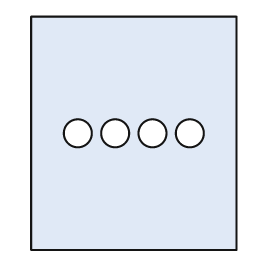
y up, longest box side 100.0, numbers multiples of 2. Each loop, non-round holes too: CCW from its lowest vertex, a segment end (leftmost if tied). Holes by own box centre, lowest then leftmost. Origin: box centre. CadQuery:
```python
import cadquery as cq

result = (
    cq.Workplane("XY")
    .moveTo(-44.0, -50.0)
    .lineTo(44.0, -50.0)
    .lineTo(44.0, 50.0)
    .lineTo(-44.0, 50.0)
    .close()
    .moveTo(-24.0, 0.0)
    .circle(6.0)
    .moveTo(-8.0, 0.0)
    .circle(6.0)
    .moveTo(8.0, 0.0)
    .circle(6.0)
    .moveTo(24.0, 0.0)
    .circle(6.0)
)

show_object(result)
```